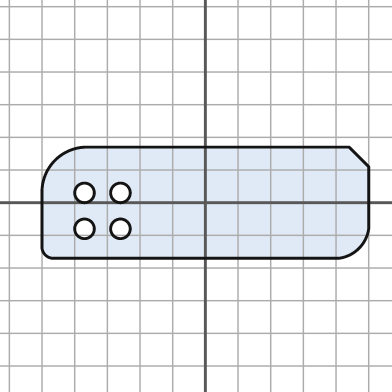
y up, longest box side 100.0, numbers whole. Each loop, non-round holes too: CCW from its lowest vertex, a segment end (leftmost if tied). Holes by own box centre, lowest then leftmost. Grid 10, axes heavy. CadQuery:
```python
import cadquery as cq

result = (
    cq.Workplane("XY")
    .moveTo(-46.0, -17.0)
    .lineTo(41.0, -17.0)
    .threePointArc((47.0, -14.0), (50.0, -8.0))
    .lineTo(50.0, 11.0)
    .lineTo(44.0, 17.0)
    .lineTo(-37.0, 17.0)
    .threePointArc((-46.0, 13.0), (-50.0, 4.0))
    .lineTo(-50.0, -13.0)
    .threePointArc((-49.0, -16.0), (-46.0, -17.0))
    .close()
    .moveTo(-37.0, -8.0)
    .circle(3.0)
    .moveTo(-26.0, -8.0)
    .circle(3.0)
    .moveTo(-37.0, 3.0)
    .circle(3.0)
    .moveTo(-26.0, 3.0)
    .circle(3.0)
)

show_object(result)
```